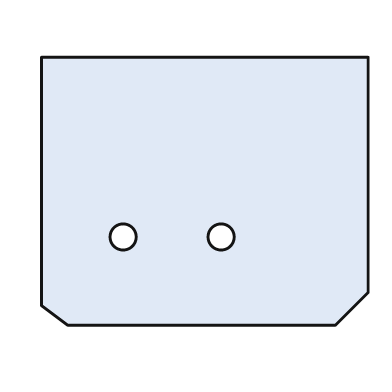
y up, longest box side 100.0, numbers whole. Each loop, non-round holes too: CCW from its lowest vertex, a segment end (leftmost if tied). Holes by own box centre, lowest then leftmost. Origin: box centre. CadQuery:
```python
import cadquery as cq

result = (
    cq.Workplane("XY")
    .moveTo(-42.0, -41.0)
    .lineTo(40.0, -41.0)
    .lineTo(50.0, -31.0)
    .lineTo(50.0, 41.0)
    .lineTo(-50.0, 41.0)
    .lineTo(-50.0, -35.0)
    .close()
    .moveTo(-25.0, -14.0)
    .circle(4.0)
    .moveTo(5.0, -14.0)
    .circle(4.0)
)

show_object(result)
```